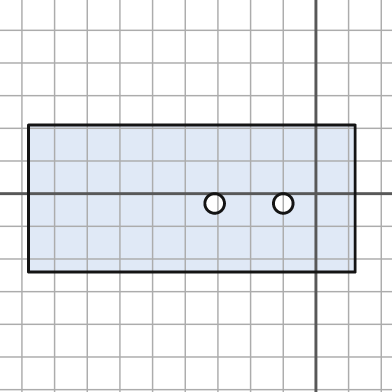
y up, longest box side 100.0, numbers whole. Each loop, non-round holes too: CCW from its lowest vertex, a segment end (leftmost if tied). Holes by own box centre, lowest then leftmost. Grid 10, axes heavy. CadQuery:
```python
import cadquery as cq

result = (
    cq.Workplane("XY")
    .moveTo(-88.0, -24.0)
    .lineTo(12.0, -24.0)
    .lineTo(12.0, 21.0)
    .lineTo(-88.0, 21.0)
    .close()
    .moveTo(-31.0, -3.0)
    .circle(3.0)
    .moveTo(-10.0, -3.0)
    .circle(3.0)
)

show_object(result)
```